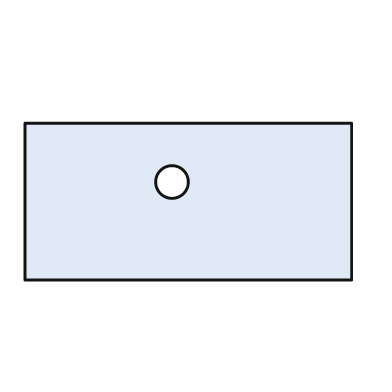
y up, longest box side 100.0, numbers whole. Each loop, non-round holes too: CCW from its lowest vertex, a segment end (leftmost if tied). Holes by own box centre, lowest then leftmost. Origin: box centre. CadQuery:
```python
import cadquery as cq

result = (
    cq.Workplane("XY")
    .moveTo(-50.0, -24.0)
    .lineTo(50.0, -24.0)
    .lineTo(50.0, 24.0)
    .lineTo(-50.0, 24.0)
    .close()
    .moveTo(-5.0, 6.0)
    .circle(5.0)
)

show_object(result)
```